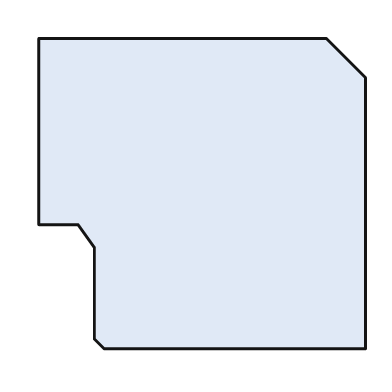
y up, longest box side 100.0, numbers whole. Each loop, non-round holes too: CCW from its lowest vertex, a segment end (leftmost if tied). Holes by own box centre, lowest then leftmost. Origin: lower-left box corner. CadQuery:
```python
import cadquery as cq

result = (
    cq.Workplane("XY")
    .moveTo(20.0, 0.0)
    .lineTo(100.0, 0.0)
    .lineTo(100.0, 83.0)
    .lineTo(88.0, 95.0)
    .lineTo(0.0, 95.0)
    .lineTo(0.0, 38.0)
    .lineTo(12.0, 38.0)
    .lineTo(17.0, 31.0)
    .lineTo(17.0, 3.0)
    .close()
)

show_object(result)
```